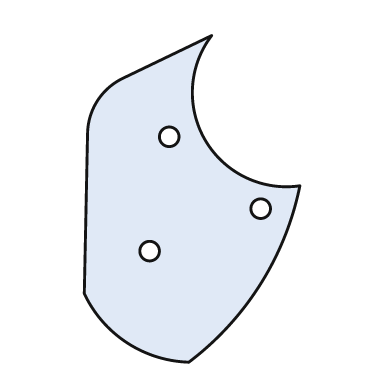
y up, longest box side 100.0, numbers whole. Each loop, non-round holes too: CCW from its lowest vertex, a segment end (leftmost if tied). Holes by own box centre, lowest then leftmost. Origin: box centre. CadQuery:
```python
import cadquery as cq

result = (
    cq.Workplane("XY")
    .moveTo(-1.0, -50.0)
    .threePointArc((21.0, -26.0), (33.0, 4.0))
    .threePointArc((4.0, 18.0), (6.0, 50.0))
    .lineTo(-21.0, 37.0)
    .threePointArc((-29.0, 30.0), (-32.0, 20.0))
    .lineTo(-33.0, -29.0)
    .threePointArc((-20.0, -44.0), (-1.0, -50.0))
    .close()
    .moveTo(-13.0, -16.0)
    .circle(3.0)
    .moveTo(21.0, -3.0)
    .circle(3.0)
    .moveTo(-7.0, 19.0)
    .circle(3.0)
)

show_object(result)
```